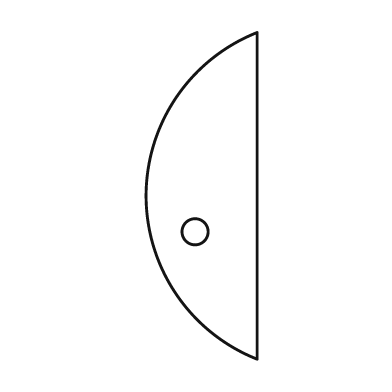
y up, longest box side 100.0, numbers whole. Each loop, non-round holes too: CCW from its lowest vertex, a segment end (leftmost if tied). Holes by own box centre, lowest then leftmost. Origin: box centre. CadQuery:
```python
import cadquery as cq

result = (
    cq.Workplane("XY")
    .moveTo(17.0, -50.0)
    .lineTo(17.0, 50.0)
    .threePointArc((-17.0, 0.0), (17.0, -50.0))
    .close()
    .moveTo(-2.0, -11.0)
    .circle(4.0)
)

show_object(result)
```